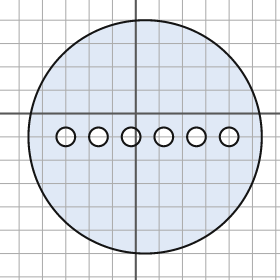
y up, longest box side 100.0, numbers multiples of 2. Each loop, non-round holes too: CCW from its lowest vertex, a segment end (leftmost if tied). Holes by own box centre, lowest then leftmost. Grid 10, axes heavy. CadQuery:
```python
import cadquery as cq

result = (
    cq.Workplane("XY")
    .moveTo(4.0, -10.0)
    .circle(50.0)
    .moveTo(-30.0, -10.0)
    .circle(4.0)
    .moveTo(-16.0, -10.0)
    .circle(4.0)
    .moveTo(-2.0, -10.0)
    .circle(4.0)
    .moveTo(12.0, -10.0)
    .circle(4.0)
    .moveTo(26.0, -10.0)
    .circle(4.0)
    .moveTo(40.0, -10.0)
    .circle(4.0)
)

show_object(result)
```